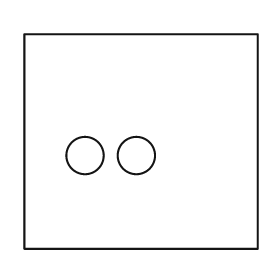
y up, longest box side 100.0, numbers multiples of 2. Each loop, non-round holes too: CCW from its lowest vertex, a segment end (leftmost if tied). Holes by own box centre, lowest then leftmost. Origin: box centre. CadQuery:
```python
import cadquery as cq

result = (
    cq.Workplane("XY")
    .moveTo(-50.0, -46.0)
    .lineTo(50.0, -46.0)
    .lineTo(50.0, 46.0)
    .lineTo(-50.0, 46.0)
    .close()
    .moveTo(-24.0, -6.0)
    .circle(8.0)
    .moveTo(-2.0, -6.0)
    .circle(8.0)
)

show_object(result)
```